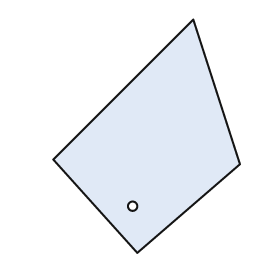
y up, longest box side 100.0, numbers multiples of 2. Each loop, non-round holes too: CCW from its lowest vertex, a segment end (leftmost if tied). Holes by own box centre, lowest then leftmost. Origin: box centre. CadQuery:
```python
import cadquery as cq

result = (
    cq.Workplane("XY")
    .moveTo(-4.0, -50.0)
    .lineTo(40.0, -12.0)
    .lineTo(20.0, 50.0)
    .lineTo(-40.0, -10.0)
    .close()
    .moveTo(-6.0, -30.0)
    .circle(2.0)
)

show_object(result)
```